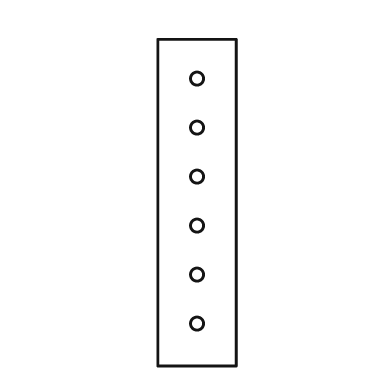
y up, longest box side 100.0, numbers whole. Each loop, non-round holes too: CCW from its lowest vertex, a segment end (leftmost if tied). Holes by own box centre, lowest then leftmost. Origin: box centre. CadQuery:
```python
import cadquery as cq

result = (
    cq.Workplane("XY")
    .moveTo(-12.0, -50.0)
    .lineTo(12.0, -50.0)
    .lineTo(12.0, 50.0)
    .lineTo(-12.0, 50.0)
    .close()
    .moveTo(0.0, -37.0)
    .circle(2.0)
    .moveTo(0.0, -22.0)
    .circle(2.0)
    .moveTo(0.0, -7.0)
    .circle(2.0)
    .moveTo(0.0, 8.0)
    .circle(2.0)
    .moveTo(0.0, 23.0)
    .circle(2.0)
    .moveTo(0.0, 38.0)
    .circle(2.0)
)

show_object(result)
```